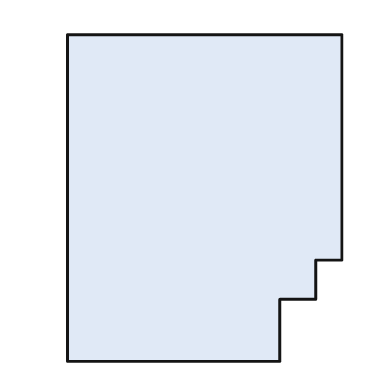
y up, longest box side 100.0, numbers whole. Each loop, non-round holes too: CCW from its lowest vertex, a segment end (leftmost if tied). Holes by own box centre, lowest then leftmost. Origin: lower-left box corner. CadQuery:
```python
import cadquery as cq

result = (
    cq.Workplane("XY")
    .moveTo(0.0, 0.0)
    .lineTo(65.0, 0.0)
    .lineTo(65.0, 19.0)
    .lineTo(76.0, 19.0)
    .lineTo(76.0, 31.0)
    .lineTo(84.0, 31.0)
    .lineTo(84.0, 100.0)
    .lineTo(0.0, 100.0)
    .close()
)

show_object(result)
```